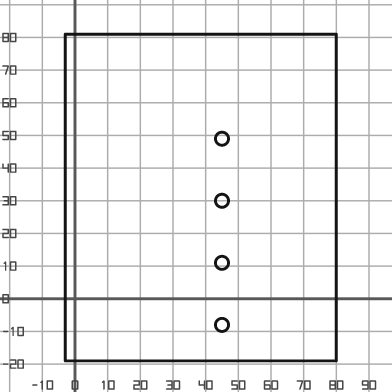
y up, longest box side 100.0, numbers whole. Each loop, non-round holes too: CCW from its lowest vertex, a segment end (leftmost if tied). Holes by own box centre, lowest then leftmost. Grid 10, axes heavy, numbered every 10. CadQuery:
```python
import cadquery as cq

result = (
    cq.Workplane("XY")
    .moveTo(-3.0, -19.0)
    .lineTo(80.0, -19.0)
    .lineTo(80.0, 81.0)
    .lineTo(-3.0, 81.0)
    .close()
    .moveTo(45.0, -8.0)
    .circle(2.0)
    .moveTo(45.0, 11.0)
    .circle(2.0)
    .moveTo(45.0, 30.0)
    .circle(2.0)
    .moveTo(45.0, 49.0)
    .circle(2.0)
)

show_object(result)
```